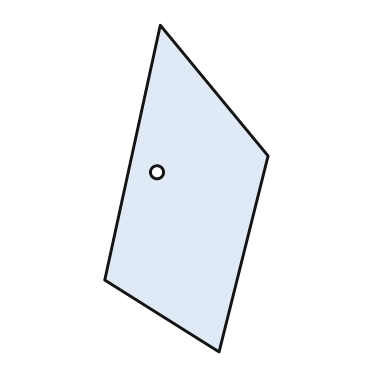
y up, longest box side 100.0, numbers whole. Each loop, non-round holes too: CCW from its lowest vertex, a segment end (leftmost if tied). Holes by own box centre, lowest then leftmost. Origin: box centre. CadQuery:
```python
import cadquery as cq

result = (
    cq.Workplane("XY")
    .moveTo(10.0, -50.0)
    .lineTo(25.0, 10.0)
    .lineTo(-8.0, 50.0)
    .lineTo(-25.0, -28.0)
    .close()
    .moveTo(-9.0, 5.0)
    .circle(2.0)
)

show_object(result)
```